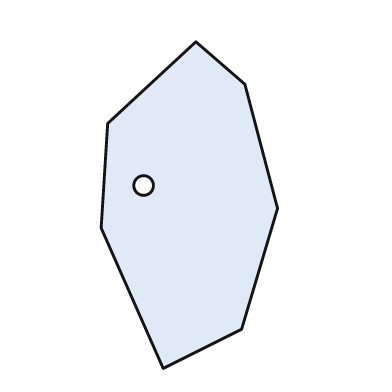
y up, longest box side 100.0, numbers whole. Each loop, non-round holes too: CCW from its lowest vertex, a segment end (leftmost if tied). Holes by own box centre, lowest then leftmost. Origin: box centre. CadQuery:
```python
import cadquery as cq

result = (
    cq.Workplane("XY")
    .moveTo(-8.0, -50.0)
    .lineTo(16.0, -38.0)
    .lineTo(27.0, -1.0)
    .lineTo(17.0, 37.0)
    .lineTo(2.0, 50.0)
    .lineTo(-25.0, 25.0)
    .lineTo(-27.0, -7.0)
    .close()
    .moveTo(-14.0, 6.0)
    .circle(3.0)
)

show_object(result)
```